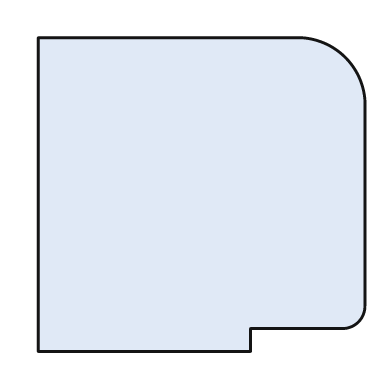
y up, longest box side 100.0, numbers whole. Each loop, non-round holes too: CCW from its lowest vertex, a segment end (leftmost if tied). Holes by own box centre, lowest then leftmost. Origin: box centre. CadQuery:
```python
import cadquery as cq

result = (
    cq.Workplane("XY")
    .moveTo(-50.0, -48.0)
    .lineTo(15.0, -48.0)
    .lineTo(15.0, -41.0)
    .lineTo(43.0, -41.0)
    .threePointArc((48.0, -39.0), (50.0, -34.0))
    .lineTo(50.0, 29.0)
    .threePointArc((44.0, 42.0), (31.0, 48.0))
    .lineTo(-50.0, 48.0)
    .close()
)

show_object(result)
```